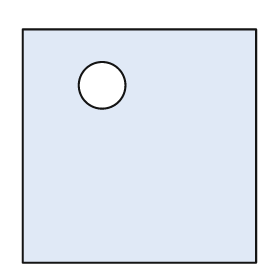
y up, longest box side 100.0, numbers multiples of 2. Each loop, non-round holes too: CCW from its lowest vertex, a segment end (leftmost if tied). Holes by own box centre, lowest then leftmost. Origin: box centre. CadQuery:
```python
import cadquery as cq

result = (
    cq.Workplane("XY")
    .moveTo(-50.0, -50.0)
    .lineTo(50.0, -50.0)
    .lineTo(50.0, 50.0)
    .lineTo(-50.0, 50.0)
    .close()
    .moveTo(-16.0, 26.0)
    .circle(10.0)
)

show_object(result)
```